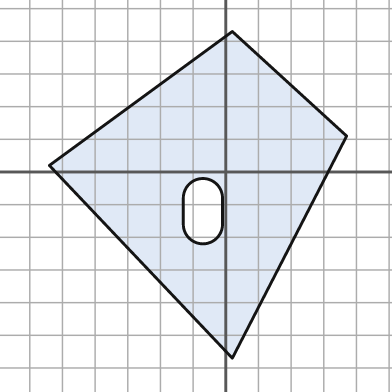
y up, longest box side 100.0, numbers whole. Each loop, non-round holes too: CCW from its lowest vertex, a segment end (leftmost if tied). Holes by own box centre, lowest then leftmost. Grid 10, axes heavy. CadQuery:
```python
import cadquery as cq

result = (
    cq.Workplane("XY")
    .moveTo(2.0, -57.0)
    .lineTo(37.0, 11.0)
    .lineTo(2.0, 43.0)
    .lineTo(-54.0, 2.0)
    .close()
    .moveTo(-13.0, -16.0)
    .threePointArc((-7.0, -22.0), (-1.0, -16.0))
    .lineTo(-1.0, -8.0)
    .threePointArc((-7.0, -2.0), (-13.0, -8.0))
    .close()
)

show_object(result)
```